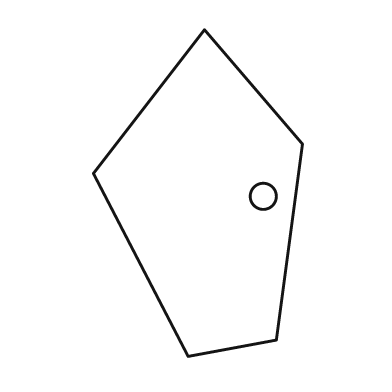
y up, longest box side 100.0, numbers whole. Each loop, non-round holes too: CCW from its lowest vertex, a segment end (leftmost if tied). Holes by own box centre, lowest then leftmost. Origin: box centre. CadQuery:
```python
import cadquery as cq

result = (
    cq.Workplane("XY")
    .moveTo(-3.0, -50.0)
    .lineTo(24.0, -45.0)
    .lineTo(32.0, 15.0)
    .lineTo(2.0, 50.0)
    .lineTo(-32.0, 6.0)
    .close()
    .moveTo(20.0, -1.0)
    .circle(4.0)
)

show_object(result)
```